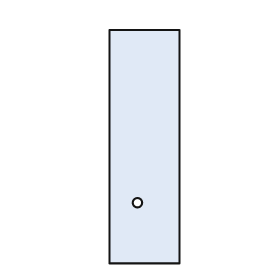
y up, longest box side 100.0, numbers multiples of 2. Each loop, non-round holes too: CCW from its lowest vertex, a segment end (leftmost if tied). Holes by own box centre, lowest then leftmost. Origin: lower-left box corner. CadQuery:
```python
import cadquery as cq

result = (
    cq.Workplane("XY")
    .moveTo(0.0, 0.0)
    .lineTo(30.0, 0.0)
    .lineTo(30.0, 100.0)
    .lineTo(0.0, 100.0)
    .close()
    .moveTo(12.0, 26.0)
    .circle(2.0)
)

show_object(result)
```